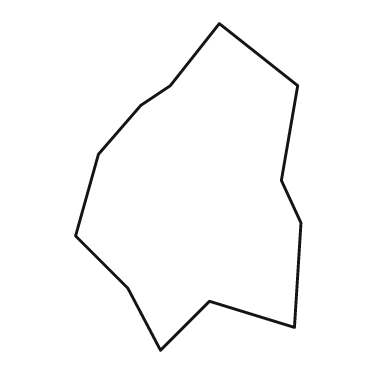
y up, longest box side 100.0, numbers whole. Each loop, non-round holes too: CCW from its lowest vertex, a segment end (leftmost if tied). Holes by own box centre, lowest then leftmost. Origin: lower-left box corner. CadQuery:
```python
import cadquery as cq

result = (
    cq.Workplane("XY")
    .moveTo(26.0, 0.0)
    .lineTo(41.0, 15.0)
    .lineTo(67.0, 7.0)
    .lineTo(69.0, 39.0)
    .lineTo(63.0, 52.0)
    .lineTo(68.0, 81.0)
    .lineTo(44.0, 100.0)
    .lineTo(29.0, 81.0)
    .lineTo(20.0, 75.0)
    .lineTo(7.0, 60.0)
    .lineTo(0.0, 35.0)
    .lineTo(16.0, 19.0)
    .close()
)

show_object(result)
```